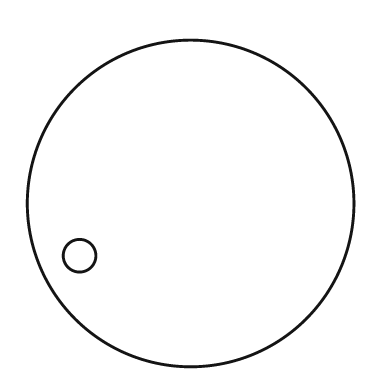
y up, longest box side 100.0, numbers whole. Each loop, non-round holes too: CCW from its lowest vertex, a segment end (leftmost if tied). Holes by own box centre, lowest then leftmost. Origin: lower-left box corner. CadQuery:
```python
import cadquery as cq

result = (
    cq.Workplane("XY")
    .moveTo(50.0, 50.0)
    .circle(50.0)
    .moveTo(16.0, 34.0)
    .circle(5.0)
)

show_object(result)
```